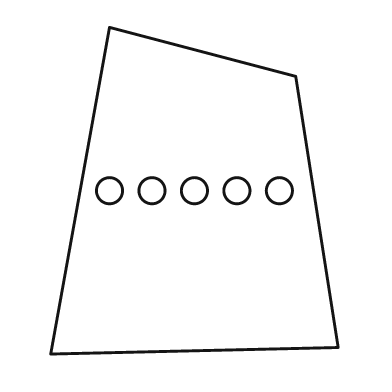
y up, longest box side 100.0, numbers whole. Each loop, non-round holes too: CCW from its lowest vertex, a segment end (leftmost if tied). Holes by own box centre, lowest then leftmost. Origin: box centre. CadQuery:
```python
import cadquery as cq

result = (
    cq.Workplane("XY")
    .moveTo(-44.0, -50.0)
    .lineTo(44.0, -48.0)
    .lineTo(31.0, 35.0)
    .lineTo(-26.0, 50.0)
    .close()
    .moveTo(-26.0, 0.0)
    .circle(4.0)
    .moveTo(-13.0, 0.0)
    .circle(4.0)
    .moveTo(0.0, 0.0)
    .circle(4.0)
    .moveTo(13.0, 0.0)
    .circle(4.0)
    .moveTo(26.0, 0.0)
    .circle(4.0)
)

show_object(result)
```